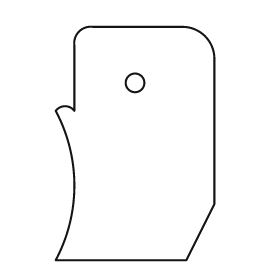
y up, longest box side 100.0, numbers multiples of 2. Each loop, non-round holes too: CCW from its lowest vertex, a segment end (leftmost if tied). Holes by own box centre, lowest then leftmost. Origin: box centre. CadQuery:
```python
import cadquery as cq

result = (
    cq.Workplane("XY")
    .moveTo(-34.0, -50.0)
    .lineTo(22.0, -50.0)
    .lineTo(34.0, -26.0)
    .lineTo(34.0, 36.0)
    .threePointArc((30.0, 46.0), (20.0, 50.0))
    .lineTo(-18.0, 50.0)
    .threePointArc((-24.0, 48.0), (-26.0, 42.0))
    .lineTo(-26.0, 14.0)
    .threePointArc((-30.0, 16.0), (-34.0, 14.0))
    .threePointArc((-26.0, -18.0), (-34.0, -50.0))
    .close()
    .moveTo(0.0, 26.0)
    .circle(4.0)
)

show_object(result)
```